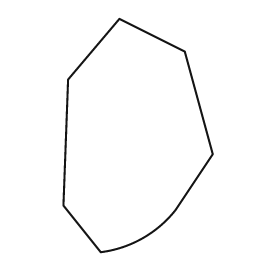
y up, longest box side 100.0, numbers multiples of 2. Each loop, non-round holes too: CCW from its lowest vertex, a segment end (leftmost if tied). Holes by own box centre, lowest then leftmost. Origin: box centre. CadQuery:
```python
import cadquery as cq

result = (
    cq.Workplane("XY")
    .moveTo(-16.0, -50.0)
    .threePointArc((2.0, -44.0), (16.0, -32.0))
    .lineTo(32.0, -8.0)
    .lineTo(20.0, 36.0)
    .lineTo(-8.0, 50.0)
    .lineTo(-30.0, 24.0)
    .lineTo(-32.0, -30.0)
    .close()
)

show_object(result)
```